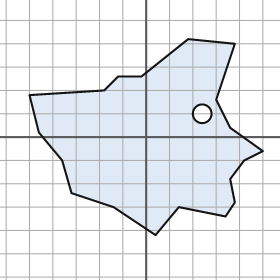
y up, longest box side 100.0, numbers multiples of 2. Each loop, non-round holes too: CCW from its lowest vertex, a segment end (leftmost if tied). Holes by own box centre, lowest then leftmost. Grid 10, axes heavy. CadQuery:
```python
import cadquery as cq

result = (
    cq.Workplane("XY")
    .moveTo(4.0, -42.0)
    .lineTo(14.0, -30.0)
    .lineTo(34.0, -34.0)
    .lineTo(38.0, -28.0)
    .lineTo(36.0, -18.0)
    .lineTo(42.0, -10.0)
    .lineTo(50.0, -6.0)
    .lineTo(36.0, 4.0)
    .lineTo(30.0, 16.0)
    .lineTo(38.0, 40.0)
    .lineTo(18.0, 42.0)
    .lineTo(-2.0, 26.0)
    .lineTo(-12.0, 26.0)
    .lineTo(-18.0, 20.0)
    .lineTo(-50.0, 18.0)
    .lineTo(-46.0, 2.0)
    .lineTo(-36.0, -10.0)
    .lineTo(-32.0, -24.0)
    .lineTo(-14.0, -30.0)
    .close()
    .moveTo(24.0, 10.0)
    .circle(4.0)
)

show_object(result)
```